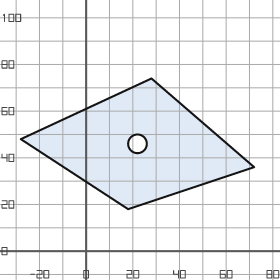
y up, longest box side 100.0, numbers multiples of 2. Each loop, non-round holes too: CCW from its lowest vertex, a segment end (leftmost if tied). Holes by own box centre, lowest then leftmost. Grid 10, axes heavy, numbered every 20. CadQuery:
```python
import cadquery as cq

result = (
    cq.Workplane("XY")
    .moveTo(18.0, 18.0)
    .lineTo(72.0, 36.0)
    .lineTo(28.0, 74.0)
    .lineTo(-28.0, 48.0)
    .close()
    .moveTo(22.0, 46.0)
    .circle(4.0)
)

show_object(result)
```